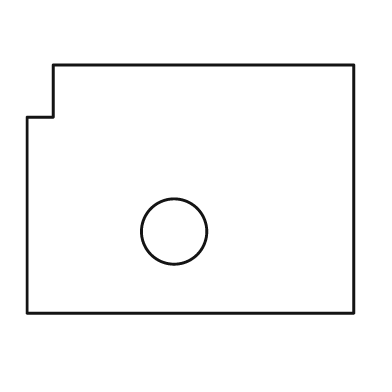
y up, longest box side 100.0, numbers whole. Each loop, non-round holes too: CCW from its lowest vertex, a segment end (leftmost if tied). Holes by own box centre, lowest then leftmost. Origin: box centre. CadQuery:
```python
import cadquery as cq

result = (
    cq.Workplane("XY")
    .moveTo(-50.0, -38.0)
    .lineTo(50.0, -38.0)
    .lineTo(50.0, 38.0)
    .lineTo(-42.0, 38.0)
    .lineTo(-42.0, 22.0)
    .lineTo(-50.0, 22.0)
    .close()
    .moveTo(-5.0, -13.0)
    .circle(10.0)
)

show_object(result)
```